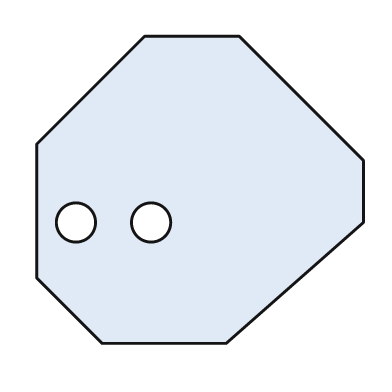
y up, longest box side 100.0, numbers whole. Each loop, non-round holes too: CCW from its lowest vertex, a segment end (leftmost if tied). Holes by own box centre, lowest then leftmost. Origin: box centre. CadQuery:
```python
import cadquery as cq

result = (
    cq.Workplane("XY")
    .moveTo(-30.0, -47.0)
    .lineTo(8.0, -47.0)
    .lineTo(50.0, -10.0)
    .lineTo(50.0, 9.0)
    .lineTo(12.0, 47.0)
    .lineTo(-17.0, 47.0)
    .lineTo(-50.0, 14.0)
    .lineTo(-50.0, -27.0)
    .close()
    .moveTo(-38.0, -10.0)
    .circle(6.0)
    .moveTo(-15.0, -10.0)
    .circle(6.0)
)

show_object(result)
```